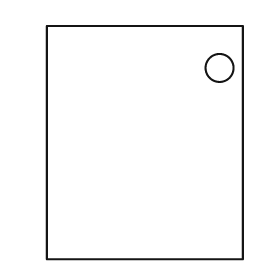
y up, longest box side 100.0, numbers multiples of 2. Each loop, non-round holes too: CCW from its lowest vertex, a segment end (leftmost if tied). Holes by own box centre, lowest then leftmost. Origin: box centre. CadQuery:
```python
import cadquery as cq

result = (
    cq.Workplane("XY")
    .moveTo(-42.0, -50.0)
    .lineTo(42.0, -50.0)
    .lineTo(42.0, 50.0)
    .lineTo(-42.0, 50.0)
    .close()
    .moveTo(32.0, 32.0)
    .circle(6.0)
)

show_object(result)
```